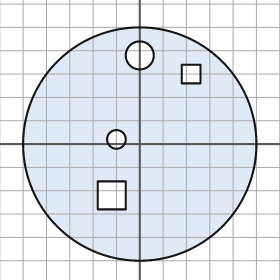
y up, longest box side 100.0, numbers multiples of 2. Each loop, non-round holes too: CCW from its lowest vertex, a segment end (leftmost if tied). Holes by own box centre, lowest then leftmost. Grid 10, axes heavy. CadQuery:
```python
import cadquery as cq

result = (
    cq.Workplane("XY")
    .moveTo(0.0, 0.0)
    .circle(50.0)
    .moveTo(-18.0, -28.0)
    .lineTo(-6.0, -28.0)
    .lineTo(-6.0, -16.0)
    .lineTo(-18.0, -16.0)
    .close()
    .moveTo(-10.0, 2.0)
    .circle(4.0)
    .moveTo(18.0, 26.0)
    .lineTo(26.0, 26.0)
    .lineTo(26.0, 34.0)
    .lineTo(18.0, 34.0)
    .close()
    .moveTo(0.0, 38.0)
    .circle(6.0)
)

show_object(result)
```